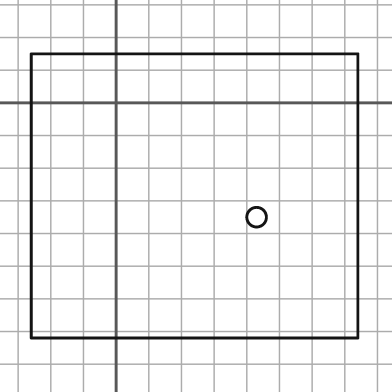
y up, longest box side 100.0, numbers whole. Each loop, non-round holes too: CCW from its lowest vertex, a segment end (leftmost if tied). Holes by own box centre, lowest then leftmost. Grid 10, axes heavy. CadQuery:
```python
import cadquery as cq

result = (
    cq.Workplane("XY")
    .moveTo(-26.0, -72.0)
    .lineTo(74.0, -72.0)
    .lineTo(74.0, 15.0)
    .lineTo(-26.0, 15.0)
    .close()
    .moveTo(43.0, -35.0)
    .circle(3.0)
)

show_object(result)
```